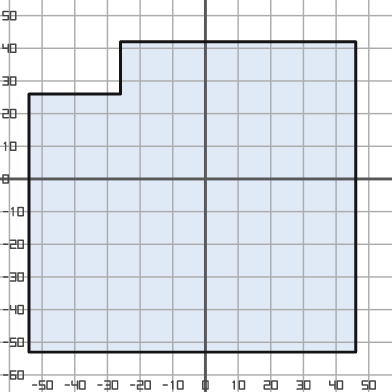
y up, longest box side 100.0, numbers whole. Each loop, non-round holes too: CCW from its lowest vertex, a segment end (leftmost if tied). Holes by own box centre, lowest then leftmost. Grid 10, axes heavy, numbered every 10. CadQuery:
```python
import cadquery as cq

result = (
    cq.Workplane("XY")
    .moveTo(-54.0, -53.0)
    .lineTo(46.0, -53.0)
    .lineTo(46.0, 42.0)
    .lineTo(-26.0, 42.0)
    .lineTo(-26.0, 26.0)
    .lineTo(-54.0, 26.0)
    .close()
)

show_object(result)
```